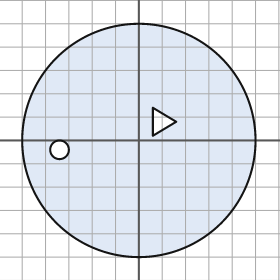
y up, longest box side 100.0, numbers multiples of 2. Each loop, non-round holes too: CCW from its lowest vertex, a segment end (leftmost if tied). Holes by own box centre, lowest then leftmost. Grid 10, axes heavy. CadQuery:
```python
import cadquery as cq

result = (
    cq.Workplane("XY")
    .moveTo(0.0, 0.0)
    .circle(50.0)
    .moveTo(-34.0, -4.0)
    .circle(4.0)
    .moveTo(6.0, 2.0)
    .lineTo(16.0, 8.0)
    .lineTo(6.0, 14.0)
    .close()
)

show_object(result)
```